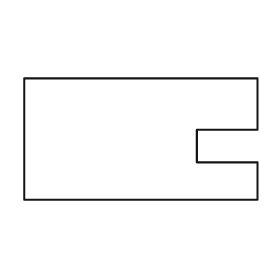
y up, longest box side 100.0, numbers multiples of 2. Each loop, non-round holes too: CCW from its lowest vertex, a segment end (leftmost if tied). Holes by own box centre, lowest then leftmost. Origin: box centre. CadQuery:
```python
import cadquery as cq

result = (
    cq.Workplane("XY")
    .moveTo(-50.0, -26.0)
    .lineTo(50.0, -26.0)
    .lineTo(50.0, -10.0)
    .lineTo(24.0, -10.0)
    .lineTo(24.0, 4.0)
    .lineTo(50.0, 4.0)
    .lineTo(50.0, 26.0)
    .lineTo(-50.0, 26.0)
    .close()
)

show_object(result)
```